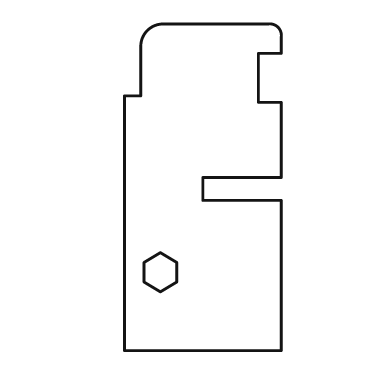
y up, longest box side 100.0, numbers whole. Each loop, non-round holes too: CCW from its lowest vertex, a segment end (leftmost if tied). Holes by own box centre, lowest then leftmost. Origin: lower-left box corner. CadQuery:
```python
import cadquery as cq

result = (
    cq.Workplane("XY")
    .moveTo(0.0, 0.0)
    .lineTo(48.0, 0.0)
    .lineTo(48.0, 46.0)
    .lineTo(24.0, 46.0)
    .lineTo(24.0, 53.0)
    .lineTo(48.0, 53.0)
    .lineTo(48.0, 76.0)
    .lineTo(41.0, 76.0)
    .lineTo(41.0, 91.0)
    .lineTo(48.0, 91.0)
    .lineTo(48.0, 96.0)
    .threePointArc((47.0, 99.0), (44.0, 100.0))
    .lineTo(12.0, 100.0)
    .threePointArc((7.0, 98.0), (5.0, 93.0))
    .lineTo(5.0, 78.0)
    .lineTo(0.0, 78.0)
    .close()
    .moveTo(11.0, 18.0)
    .lineTo(16.0, 21.0)
    .lineTo(16.0, 27.0)
    .lineTo(11.0, 30.0)
    .lineTo(6.0, 27.0)
    .lineTo(6.0, 21.0)
    .close()
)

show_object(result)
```